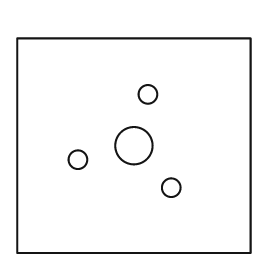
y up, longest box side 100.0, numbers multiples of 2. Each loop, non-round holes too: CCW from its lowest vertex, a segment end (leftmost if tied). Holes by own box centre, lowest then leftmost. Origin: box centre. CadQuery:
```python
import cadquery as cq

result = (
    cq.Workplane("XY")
    .moveTo(-50.0, -46.0)
    .lineTo(50.0, -46.0)
    .lineTo(50.0, 46.0)
    .lineTo(-50.0, 46.0)
    .close()
    .moveTo(16.0, -18.0)
    .circle(4.0)
    .moveTo(-24.0, -6.0)
    .circle(4.0)
    .moveTo(0.0, 0.0)
    .circle(8.0)
    .moveTo(6.0, 22.0)
    .circle(4.0)
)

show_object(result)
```